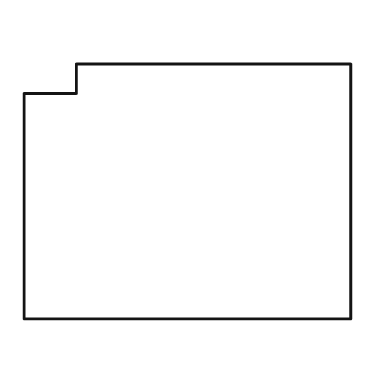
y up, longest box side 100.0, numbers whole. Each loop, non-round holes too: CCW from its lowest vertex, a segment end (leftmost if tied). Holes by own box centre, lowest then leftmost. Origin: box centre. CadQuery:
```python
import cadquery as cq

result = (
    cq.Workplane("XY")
    .moveTo(-50.0, -39.0)
    .lineTo(50.0, -39.0)
    .lineTo(50.0, 39.0)
    .lineTo(-34.0, 39.0)
    .lineTo(-34.0, 30.0)
    .lineTo(-50.0, 30.0)
    .close()
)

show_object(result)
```